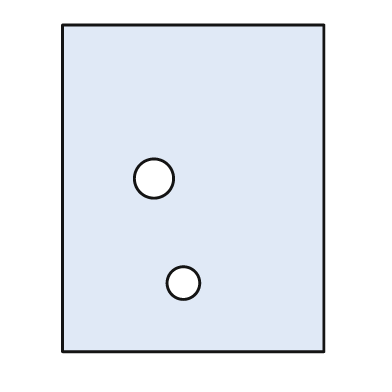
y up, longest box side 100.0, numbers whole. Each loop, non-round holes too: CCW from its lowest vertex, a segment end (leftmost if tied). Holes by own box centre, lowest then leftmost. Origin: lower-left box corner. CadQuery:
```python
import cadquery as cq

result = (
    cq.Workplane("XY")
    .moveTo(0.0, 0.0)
    .lineTo(80.0, 0.0)
    .lineTo(80.0, 100.0)
    .lineTo(0.0, 100.0)
    .close()
    .moveTo(37.0, 21.0)
    .circle(5.0)
    .moveTo(28.0, 53.0)
    .circle(6.0)
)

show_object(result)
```